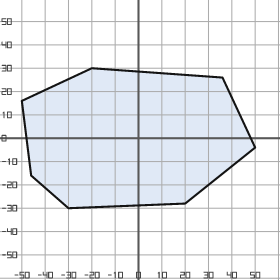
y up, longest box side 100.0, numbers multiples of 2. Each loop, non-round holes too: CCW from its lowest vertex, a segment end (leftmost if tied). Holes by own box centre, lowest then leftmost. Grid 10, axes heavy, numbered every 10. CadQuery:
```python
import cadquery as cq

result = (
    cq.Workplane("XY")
    .moveTo(-30.0, -30.0)
    .lineTo(20.0, -28.0)
    .lineTo(50.0, -4.0)
    .lineTo(36.0, 26.0)
    .lineTo(-20.0, 30.0)
    .lineTo(-50.0, 16.0)
    .lineTo(-46.0, -16.0)
    .close()
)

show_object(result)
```